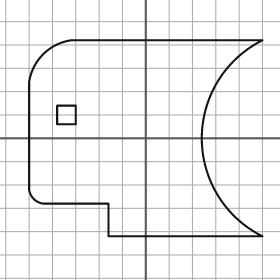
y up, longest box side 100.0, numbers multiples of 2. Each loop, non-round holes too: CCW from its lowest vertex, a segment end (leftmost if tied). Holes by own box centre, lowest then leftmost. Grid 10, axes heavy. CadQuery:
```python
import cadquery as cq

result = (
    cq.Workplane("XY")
    .moveTo(-16.0, -42.0)
    .lineTo(50.0, -42.0)
    .threePointArc((24.0, 0.0), (50.0, 42.0))
    .lineTo(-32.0, 42.0)
    .threePointArc((-44.0, 36.0), (-50.0, 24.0))
    .lineTo(-50.0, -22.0)
    .threePointArc((-48.0, -26.0), (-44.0, -28.0))
    .lineTo(-16.0, -28.0)
    .close()
    .moveTo(-38.0, 6.0)
    .lineTo(-30.0, 6.0)
    .lineTo(-30.0, 14.0)
    .lineTo(-38.0, 14.0)
    .close()
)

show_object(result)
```